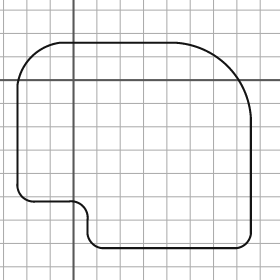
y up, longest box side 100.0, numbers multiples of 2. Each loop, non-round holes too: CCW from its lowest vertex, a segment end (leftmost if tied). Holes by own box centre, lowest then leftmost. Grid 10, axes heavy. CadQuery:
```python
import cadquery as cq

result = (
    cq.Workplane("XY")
    .moveTo(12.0, -72.0)
    .lineTo(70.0, -72.0)
    .threePointArc((74.0, -70.0), (76.0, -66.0))
    .lineTo(76.0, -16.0)
    .threePointArc((66.0, 6.0), (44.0, 16.0))
    .lineTo(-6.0, 16.0)
    .threePointArc((-18.0, 10.0), (-24.0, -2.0))
    .lineTo(-24.0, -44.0)
    .threePointArc((-22.0, -50.0), (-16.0, -52.0))
    .lineTo(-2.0, -52.0)
    .threePointArc((4.0, -54.0), (6.0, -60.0))
    .lineTo(6.0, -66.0)
    .threePointArc((8.0, -70.0), (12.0, -72.0))
    .close()
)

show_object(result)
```